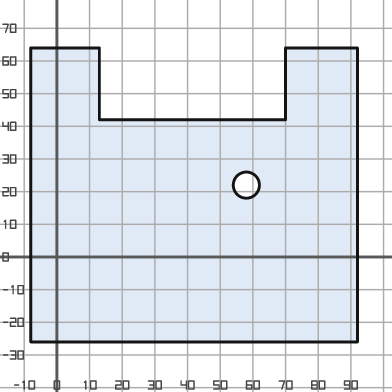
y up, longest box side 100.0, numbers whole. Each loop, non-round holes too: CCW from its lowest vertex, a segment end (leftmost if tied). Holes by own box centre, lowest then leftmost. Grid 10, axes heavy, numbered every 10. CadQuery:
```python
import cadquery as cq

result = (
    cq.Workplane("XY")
    .moveTo(-8.0, -26.0)
    .lineTo(92.0, -26.0)
    .lineTo(92.0, 64.0)
    .lineTo(70.0, 64.0)
    .lineTo(70.0, 42.0)
    .lineTo(13.0, 42.0)
    .lineTo(13.0, 64.0)
    .lineTo(-8.0, 64.0)
    .close()
    .moveTo(58.0, 22.0)
    .circle(4.0)
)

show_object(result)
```